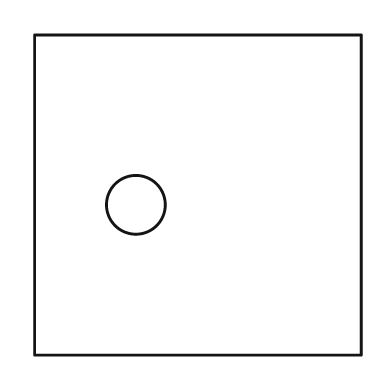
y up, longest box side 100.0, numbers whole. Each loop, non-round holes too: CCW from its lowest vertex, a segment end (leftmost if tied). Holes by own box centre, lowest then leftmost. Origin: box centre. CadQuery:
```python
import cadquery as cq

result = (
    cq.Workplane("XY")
    .moveTo(-50.0, -49.0)
    .lineTo(50.0, -49.0)
    .lineTo(50.0, 49.0)
    .lineTo(-50.0, 49.0)
    .close()
    .moveTo(-19.0, -3.0)
    .circle(9.0)
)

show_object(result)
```